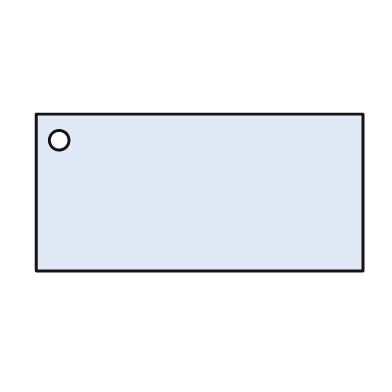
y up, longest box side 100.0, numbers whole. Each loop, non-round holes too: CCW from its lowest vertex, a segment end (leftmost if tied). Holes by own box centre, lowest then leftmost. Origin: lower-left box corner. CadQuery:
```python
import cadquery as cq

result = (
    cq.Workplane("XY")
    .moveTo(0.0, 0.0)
    .lineTo(100.0, 0.0)
    .lineTo(100.0, 48.0)
    .lineTo(0.0, 48.0)
    .close()
    .moveTo(7.0, 40.0)
    .circle(3.0)
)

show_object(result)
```